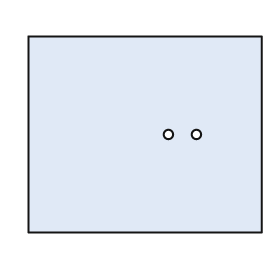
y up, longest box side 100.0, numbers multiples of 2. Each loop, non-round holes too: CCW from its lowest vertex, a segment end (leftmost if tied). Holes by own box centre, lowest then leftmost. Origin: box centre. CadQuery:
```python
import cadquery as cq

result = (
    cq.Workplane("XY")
    .moveTo(-50.0, -42.0)
    .lineTo(50.0, -42.0)
    .lineTo(50.0, 42.0)
    .lineTo(-50.0, 42.0)
    .close()
    .moveTo(10.0, 0.0)
    .circle(2.0)
    .moveTo(22.0, 0.0)
    .circle(2.0)
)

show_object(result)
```